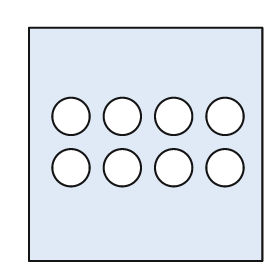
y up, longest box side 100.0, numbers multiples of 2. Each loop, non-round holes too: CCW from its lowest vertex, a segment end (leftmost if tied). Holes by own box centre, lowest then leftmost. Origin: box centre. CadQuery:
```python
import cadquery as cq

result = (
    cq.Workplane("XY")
    .moveTo(-50.0, -50.0)
    .lineTo(50.0, -50.0)
    .lineTo(50.0, 50.0)
    .lineTo(-50.0, 50.0)
    .close()
    .moveTo(-32.0, -10.0)
    .circle(8.0)
    .moveTo(-10.0, -10.0)
    .circle(8.0)
    .moveTo(12.0, -10.0)
    .circle(8.0)
    .moveTo(34.0, -10.0)
    .circle(8.0)
    .moveTo(-32.0, 12.0)
    .circle(8.0)
    .moveTo(-10.0, 12.0)
    .circle(8.0)
    .moveTo(12.0, 12.0)
    .circle(8.0)
    .moveTo(34.0, 12.0)
    .circle(8.0)
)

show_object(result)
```